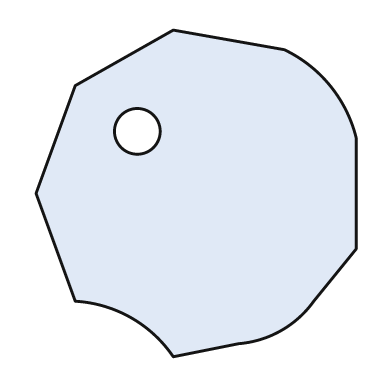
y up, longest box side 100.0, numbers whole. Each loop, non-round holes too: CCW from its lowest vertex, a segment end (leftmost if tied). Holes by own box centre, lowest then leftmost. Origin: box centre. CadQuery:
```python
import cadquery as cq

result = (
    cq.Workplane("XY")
    .moveTo(-7.0, -50.0)
    .lineTo(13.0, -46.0)
    .threePointArc((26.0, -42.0), (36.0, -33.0))
    .lineTo(49.0, -17.0)
    .lineTo(49.0, 17.0)
    .threePointArc((41.0, 33.0), (27.0, 44.0))
    .lineTo(-7.0, 50.0)
    .lineTo(-37.0, 33.0)
    .lineTo(-49.0, 0.0)
    .lineTo(-37.0, -33.0)
    .threePointArc((-20.0, -38.0), (-7.0, -50.0))
    .close()
    .moveTo(-18.0, 19.0)
    .circle(7.0)
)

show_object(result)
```